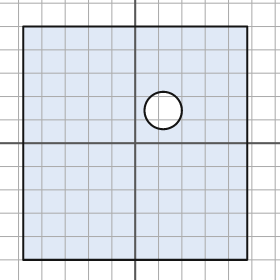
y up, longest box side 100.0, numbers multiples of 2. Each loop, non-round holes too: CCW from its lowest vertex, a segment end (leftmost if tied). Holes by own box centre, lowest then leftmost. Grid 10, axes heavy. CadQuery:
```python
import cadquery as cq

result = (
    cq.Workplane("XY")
    .moveTo(-48.0, -50.0)
    .lineTo(48.0, -50.0)
    .lineTo(48.0, 50.0)
    .lineTo(-48.0, 50.0)
    .close()
    .moveTo(12.0, 14.0)
    .circle(8.0)
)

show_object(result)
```